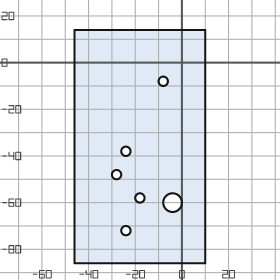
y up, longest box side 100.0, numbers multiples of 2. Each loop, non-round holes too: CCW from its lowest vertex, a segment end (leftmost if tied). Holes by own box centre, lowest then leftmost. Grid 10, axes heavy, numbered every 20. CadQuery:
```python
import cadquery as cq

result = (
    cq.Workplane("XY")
    .moveTo(-46.0, -86.0)
    .lineTo(10.0, -86.0)
    .lineTo(10.0, 14.0)
    .lineTo(-46.0, 14.0)
    .close()
    .moveTo(-24.0, -72.0)
    .circle(2.0)
    .moveTo(-4.0, -60.0)
    .circle(4.0)
    .moveTo(-18.0, -58.0)
    .circle(2.0)
    .moveTo(-28.0, -48.0)
    .circle(2.0)
    .moveTo(-24.0, -38.0)
    .circle(2.0)
    .moveTo(-8.0, -8.0)
    .circle(2.0)
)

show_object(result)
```